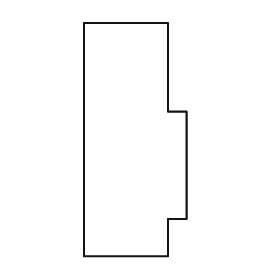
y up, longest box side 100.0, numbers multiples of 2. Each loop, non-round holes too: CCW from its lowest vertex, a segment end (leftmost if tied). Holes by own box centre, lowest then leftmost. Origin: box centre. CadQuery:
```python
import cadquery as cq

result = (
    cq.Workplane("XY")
    .moveTo(-22.0, -50.0)
    .lineTo(14.0, -50.0)
    .lineTo(14.0, -34.0)
    .lineTo(22.0, -34.0)
    .lineTo(22.0, 12.0)
    .lineTo(14.0, 12.0)
    .lineTo(14.0, 50.0)
    .lineTo(-22.0, 50.0)
    .close()
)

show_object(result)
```